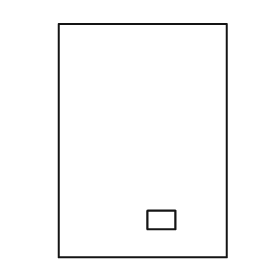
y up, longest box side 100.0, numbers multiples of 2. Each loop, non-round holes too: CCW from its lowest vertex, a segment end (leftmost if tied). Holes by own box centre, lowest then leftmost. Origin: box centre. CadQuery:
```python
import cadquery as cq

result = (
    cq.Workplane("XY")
    .moveTo(-36.0, -50.0)
    .lineTo(36.0, -50.0)
    .lineTo(36.0, 50.0)
    .lineTo(-36.0, 50.0)
    .close()
    .moveTo(2.0, -38.0)
    .lineTo(14.0, -38.0)
    .lineTo(14.0, -30.0)
    .lineTo(2.0, -30.0)
    .close()
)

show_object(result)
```